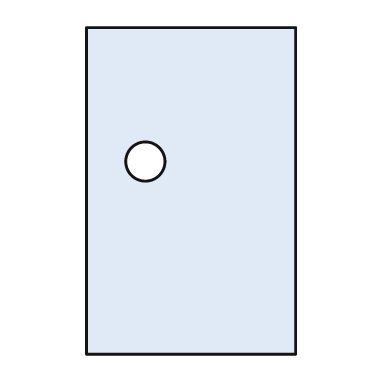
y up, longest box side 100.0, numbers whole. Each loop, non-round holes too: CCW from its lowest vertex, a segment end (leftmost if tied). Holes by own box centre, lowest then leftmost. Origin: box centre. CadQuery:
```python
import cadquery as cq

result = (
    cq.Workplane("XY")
    .moveTo(-32.0, -50.0)
    .lineTo(32.0, -50.0)
    .lineTo(32.0, 50.0)
    .lineTo(-32.0, 50.0)
    .close()
    .moveTo(-14.0, 9.0)
    .circle(6.0)
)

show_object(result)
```